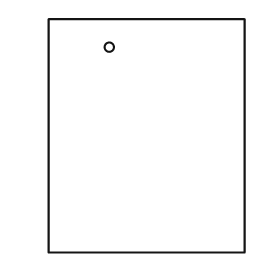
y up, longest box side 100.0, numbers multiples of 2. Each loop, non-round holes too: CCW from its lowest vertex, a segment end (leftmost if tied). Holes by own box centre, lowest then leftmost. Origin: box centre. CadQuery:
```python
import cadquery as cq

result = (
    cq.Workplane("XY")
    .moveTo(-42.0, -50.0)
    .lineTo(42.0, -50.0)
    .lineTo(42.0, 50.0)
    .lineTo(-42.0, 50.0)
    .close()
    .moveTo(-16.0, 38.0)
    .circle(2.0)
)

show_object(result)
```